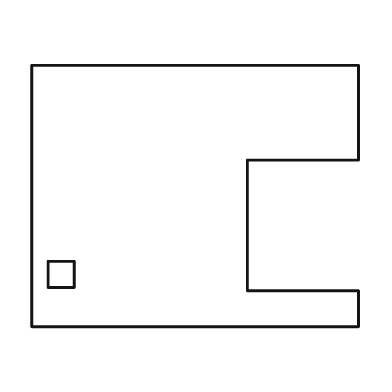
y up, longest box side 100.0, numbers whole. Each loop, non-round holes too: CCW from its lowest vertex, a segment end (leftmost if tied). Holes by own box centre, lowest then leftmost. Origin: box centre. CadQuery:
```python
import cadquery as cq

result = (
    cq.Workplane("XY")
    .moveTo(-50.0, -40.0)
    .lineTo(50.0, -40.0)
    .lineTo(50.0, -29.0)
    .lineTo(16.0, -29.0)
    .lineTo(16.0, 11.0)
    .lineTo(50.0, 11.0)
    .lineTo(50.0, 40.0)
    .lineTo(-50.0, 40.0)
    .close()
    .moveTo(-45.0, -28.0)
    .lineTo(-37.0, -28.0)
    .lineTo(-37.0, -20.0)
    .lineTo(-45.0, -20.0)
    .close()
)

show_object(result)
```